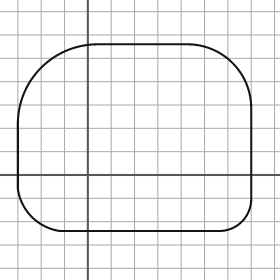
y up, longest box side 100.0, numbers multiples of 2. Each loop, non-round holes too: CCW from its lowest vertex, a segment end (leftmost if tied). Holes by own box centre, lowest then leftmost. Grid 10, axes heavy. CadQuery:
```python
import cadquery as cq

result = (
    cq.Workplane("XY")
    .moveTo(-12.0, -24.0)
    .lineTo(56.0, -24.0)
    .threePointArc((66.0, -20.0), (70.0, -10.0))
    .lineTo(70.0, 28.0)
    .threePointArc((62.0, 48.0), (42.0, 56.0))
    .lineTo(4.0, 56.0)
    .threePointArc((-20.0, 46.0), (-30.0, 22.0))
    .lineTo(-30.0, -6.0)
    .threePointArc((-24.0, -18.0), (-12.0, -24.0))
    .close()
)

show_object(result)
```